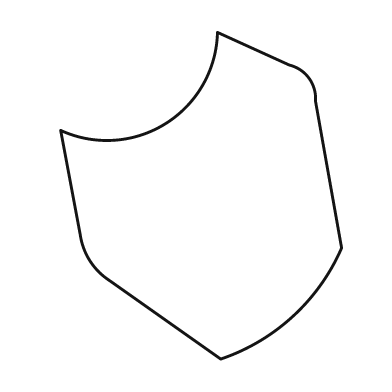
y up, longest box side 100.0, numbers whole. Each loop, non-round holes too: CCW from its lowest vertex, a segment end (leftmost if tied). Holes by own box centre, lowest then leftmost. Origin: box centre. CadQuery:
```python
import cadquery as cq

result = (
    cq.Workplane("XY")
    .moveTo(6.0, -50.0)
    .threePointArc((28.0, -37.0), (43.0, -16.0))
    .lineTo(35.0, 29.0)
    .threePointArc((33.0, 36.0), (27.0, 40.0))
    .lineTo(5.0, 50.0)
    .threePointArc((-11.0, 22.0), (-43.0, 20.0))
    .lineTo(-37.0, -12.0)
    .threePointArc((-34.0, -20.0), (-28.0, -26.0))
    .close()
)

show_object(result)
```